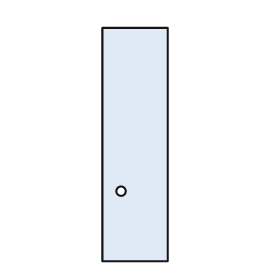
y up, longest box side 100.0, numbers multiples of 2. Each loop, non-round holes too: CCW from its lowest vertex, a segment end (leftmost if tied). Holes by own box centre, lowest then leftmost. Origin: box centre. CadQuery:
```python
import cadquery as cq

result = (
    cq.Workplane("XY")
    .moveTo(-14.0, -50.0)
    .lineTo(14.0, -50.0)
    .lineTo(14.0, 50.0)
    .lineTo(-14.0, 50.0)
    .close()
    .moveTo(-6.0, -20.0)
    .circle(2.0)
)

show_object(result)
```